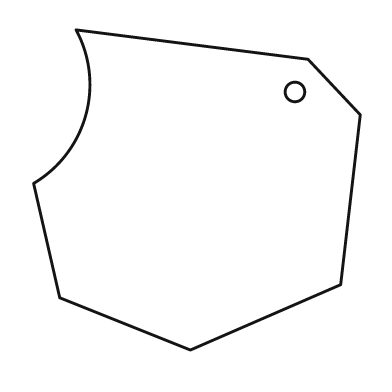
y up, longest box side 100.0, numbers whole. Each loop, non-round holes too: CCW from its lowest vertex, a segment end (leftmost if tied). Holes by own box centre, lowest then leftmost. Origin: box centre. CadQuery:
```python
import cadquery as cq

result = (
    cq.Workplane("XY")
    .moveTo(-2.0, -49.0)
    .lineTo(44.0, -29.0)
    .lineTo(50.0, 23.0)
    .lineTo(34.0, 40.0)
    .lineTo(-37.0, 49.0)
    .threePointArc((-34.0, 23.0), (-50.0, 2.0))
    .lineTo(-42.0, -33.0)
    .close()
    .moveTo(30.0, 30.0)
    .circle(3.0)
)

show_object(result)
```